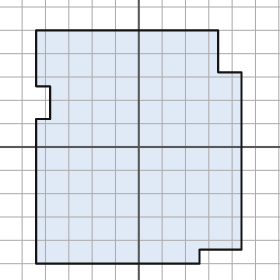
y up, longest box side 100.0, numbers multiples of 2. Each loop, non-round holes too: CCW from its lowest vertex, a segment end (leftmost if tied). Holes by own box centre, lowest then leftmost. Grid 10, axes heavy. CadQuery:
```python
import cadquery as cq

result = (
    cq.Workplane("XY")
    .moveTo(-44.0, -50.0)
    .lineTo(26.0, -50.0)
    .lineTo(26.0, -44.0)
    .lineTo(44.0, -44.0)
    .lineTo(44.0, 32.0)
    .lineTo(34.0, 32.0)
    .lineTo(34.0, 50.0)
    .lineTo(-44.0, 50.0)
    .lineTo(-44.0, 26.0)
    .lineTo(-38.0, 26.0)
    .lineTo(-38.0, 12.0)
    .lineTo(-44.0, 12.0)
    .close()
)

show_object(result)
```